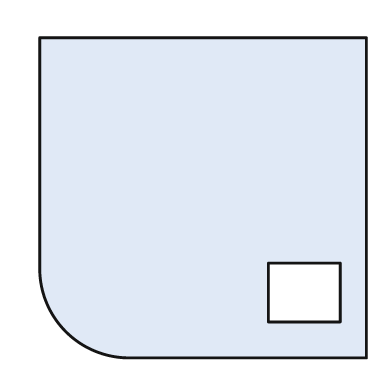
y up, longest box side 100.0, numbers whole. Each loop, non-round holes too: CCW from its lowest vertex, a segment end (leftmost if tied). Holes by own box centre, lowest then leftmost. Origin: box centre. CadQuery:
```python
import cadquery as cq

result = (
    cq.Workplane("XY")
    .moveTo(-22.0, -49.0)
    .lineTo(50.0, -49.0)
    .lineTo(50.0, 49.0)
    .lineTo(-50.0, 49.0)
    .lineTo(-50.0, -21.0)
    .threePointArc((-42.0, -41.0), (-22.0, -49.0))
    .close()
    .moveTo(20.0, -38.0)
    .lineTo(42.0, -38.0)
    .lineTo(42.0, -20.0)
    .lineTo(20.0, -20.0)
    .close()
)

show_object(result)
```